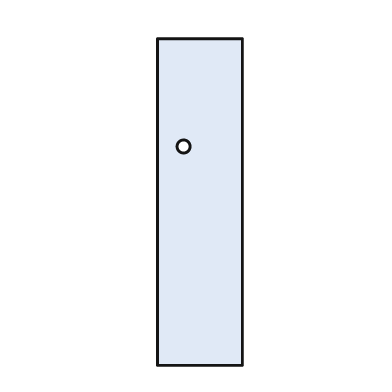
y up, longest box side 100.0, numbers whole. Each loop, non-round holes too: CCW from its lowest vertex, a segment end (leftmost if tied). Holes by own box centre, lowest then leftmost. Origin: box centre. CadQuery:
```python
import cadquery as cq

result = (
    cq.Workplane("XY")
    .moveTo(-13.0, -50.0)
    .lineTo(13.0, -50.0)
    .lineTo(13.0, 50.0)
    .lineTo(-13.0, 50.0)
    .close()
    .moveTo(-5.0, 17.0)
    .circle(2.0)
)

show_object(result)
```